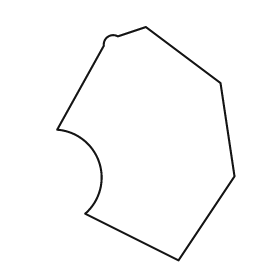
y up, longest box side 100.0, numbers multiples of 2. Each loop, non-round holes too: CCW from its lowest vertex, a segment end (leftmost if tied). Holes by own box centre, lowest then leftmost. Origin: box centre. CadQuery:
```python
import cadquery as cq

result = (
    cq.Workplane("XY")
    .moveTo(14.0, -50.0)
    .lineTo(38.0, -14.0)
    .lineTo(32.0, 26.0)
    .lineTo(0.0, 50.0)
    .lineTo(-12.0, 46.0)
    .threePointArc((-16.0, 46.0), (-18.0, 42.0))
    .lineTo(-38.0, 6.0)
    .threePointArc((-20.0, -8.0), (-26.0, -30.0))
    .close()
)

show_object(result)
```